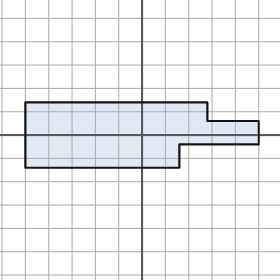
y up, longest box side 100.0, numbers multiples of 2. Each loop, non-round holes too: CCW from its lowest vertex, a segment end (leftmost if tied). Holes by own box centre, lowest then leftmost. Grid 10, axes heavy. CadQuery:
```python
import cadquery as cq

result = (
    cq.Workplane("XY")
    .moveTo(-50.0, -14.0)
    .lineTo(16.0, -14.0)
    .lineTo(16.0, -4.0)
    .lineTo(50.0, -4.0)
    .lineTo(50.0, 6.0)
    .lineTo(28.0, 6.0)
    .lineTo(28.0, 14.0)
    .lineTo(-50.0, 14.0)
    .close()
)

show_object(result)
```